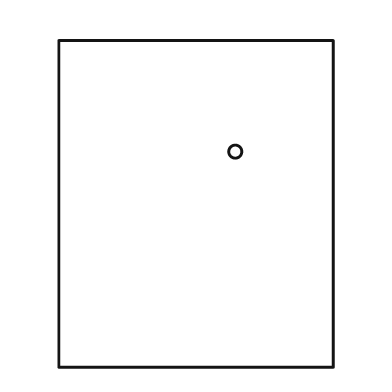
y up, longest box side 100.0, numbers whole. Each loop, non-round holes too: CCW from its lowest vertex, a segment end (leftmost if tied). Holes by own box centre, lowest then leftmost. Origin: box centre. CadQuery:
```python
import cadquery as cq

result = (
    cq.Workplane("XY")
    .moveTo(-42.0, -50.0)
    .lineTo(42.0, -50.0)
    .lineTo(42.0, 50.0)
    .lineTo(-42.0, 50.0)
    .close()
    .moveTo(12.0, 16.0)
    .circle(2.0)
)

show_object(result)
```